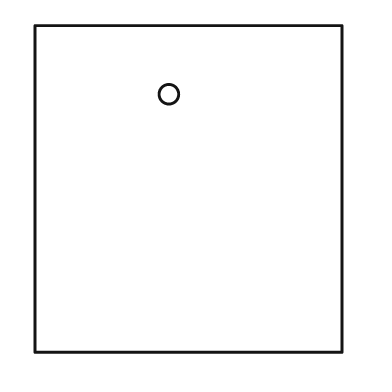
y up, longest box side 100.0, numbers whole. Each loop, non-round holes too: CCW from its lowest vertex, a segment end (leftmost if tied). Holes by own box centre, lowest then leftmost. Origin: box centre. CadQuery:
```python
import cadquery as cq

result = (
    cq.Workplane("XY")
    .moveTo(-47.0, -50.0)
    .lineTo(47.0, -50.0)
    .lineTo(47.0, 50.0)
    .lineTo(-47.0, 50.0)
    .close()
    .moveTo(-6.0, 29.0)
    .circle(3.0)
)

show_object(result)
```